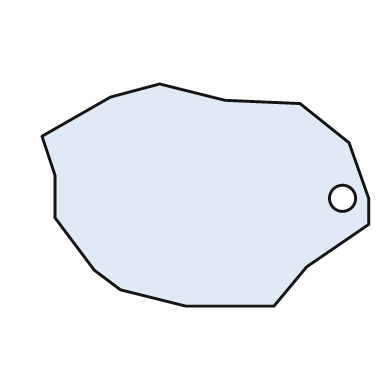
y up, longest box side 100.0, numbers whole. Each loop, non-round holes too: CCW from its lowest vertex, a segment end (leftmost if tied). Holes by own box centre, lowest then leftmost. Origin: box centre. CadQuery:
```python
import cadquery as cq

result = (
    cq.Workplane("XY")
    .moveTo(-6.0, -34.0)
    .lineTo(21.0, -34.0)
    .lineTo(31.0, -22.0)
    .lineTo(50.0, -9.0)
    .lineTo(50.0, -1.0)
    .lineTo(44.0, 16.0)
    .lineTo(29.0, 28.0)
    .lineTo(6.0, 29.0)
    .lineTo(-14.0, 34.0)
    .lineTo(-29.0, 30.0)
    .lineTo(-50.0, 18.0)
    .lineTo(-46.0, 6.0)
    .lineTo(-46.0, -7.0)
    .lineTo(-34.0, -23.0)
    .lineTo(-26.0, -29.0)
    .close()
    .moveTo(42.0, -1.0)
    .circle(4.0)
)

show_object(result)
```